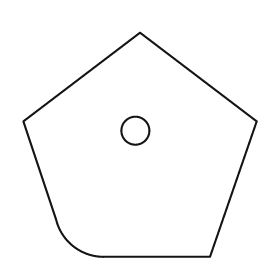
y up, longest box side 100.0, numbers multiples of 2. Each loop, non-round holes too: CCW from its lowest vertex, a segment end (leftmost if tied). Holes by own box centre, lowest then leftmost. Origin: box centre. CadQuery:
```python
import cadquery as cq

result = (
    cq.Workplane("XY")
    .moveTo(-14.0, -48.0)
    .lineTo(30.0, -48.0)
    .lineTo(50.0, 10.0)
    .lineTo(0.0, 48.0)
    .lineTo(-50.0, 10.0)
    .lineTo(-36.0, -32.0)
    .threePointArc((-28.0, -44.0), (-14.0, -48.0))
    .close()
    .moveTo(-2.0, 6.0)
    .circle(6.0)
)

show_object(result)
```